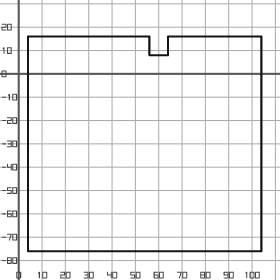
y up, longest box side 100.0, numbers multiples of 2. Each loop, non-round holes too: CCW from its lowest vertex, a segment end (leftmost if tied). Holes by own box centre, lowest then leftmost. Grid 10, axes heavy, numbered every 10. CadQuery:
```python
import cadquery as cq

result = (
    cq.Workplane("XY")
    .moveTo(4.0, -76.0)
    .lineTo(104.0, -76.0)
    .lineTo(104.0, 16.0)
    .lineTo(64.0, 16.0)
    .lineTo(64.0, 8.0)
    .lineTo(56.0, 8.0)
    .lineTo(56.0, 16.0)
    .lineTo(4.0, 16.0)
    .close()
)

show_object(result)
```